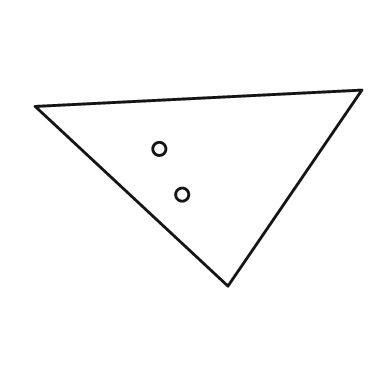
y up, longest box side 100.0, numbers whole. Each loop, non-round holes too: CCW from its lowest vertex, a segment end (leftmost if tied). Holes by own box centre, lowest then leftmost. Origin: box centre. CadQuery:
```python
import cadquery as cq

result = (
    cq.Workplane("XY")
    .moveTo(9.0, -30.0)
    .lineTo(50.0, 30.0)
    .lineTo(-50.0, 25.0)
    .close()
    .moveTo(-5.0, -2.0)
    .circle(2.0)
    .moveTo(-12.0, 12.0)
    .circle(2.0)
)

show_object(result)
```